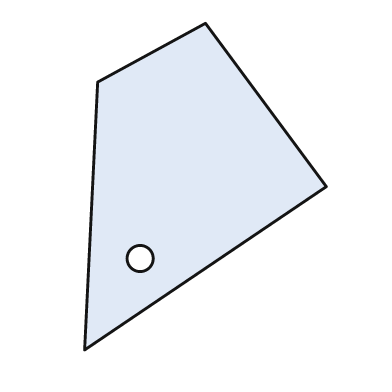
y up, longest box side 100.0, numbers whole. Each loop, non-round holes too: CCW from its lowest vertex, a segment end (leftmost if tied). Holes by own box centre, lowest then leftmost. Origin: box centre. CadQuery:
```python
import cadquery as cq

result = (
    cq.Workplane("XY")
    .moveTo(-37.0, -50.0)
    .lineTo(37.0, 0.0)
    .lineTo(0.0, 50.0)
    .lineTo(-33.0, 32.0)
    .close()
    .moveTo(-20.0, -22.0)
    .circle(4.0)
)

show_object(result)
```